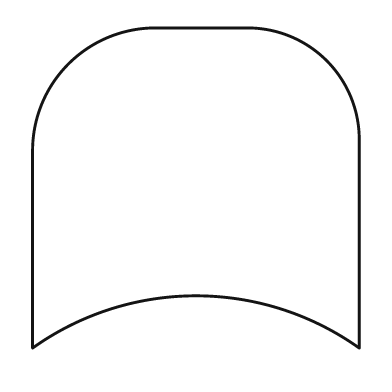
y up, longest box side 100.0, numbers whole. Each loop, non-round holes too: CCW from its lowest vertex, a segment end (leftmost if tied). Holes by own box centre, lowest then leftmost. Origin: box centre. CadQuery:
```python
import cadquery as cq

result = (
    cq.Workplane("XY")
    .moveTo(-50.0, -49.0)
    .threePointArc((0.0, -33.0), (50.0, -49.0))
    .lineTo(50.0, 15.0)
    .threePointArc((40.0, 39.0), (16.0, 49.0))
    .lineTo(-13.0, 49.0)
    .threePointArc((-39.0, 38.0), (-50.0, 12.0))
    .close()
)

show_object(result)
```